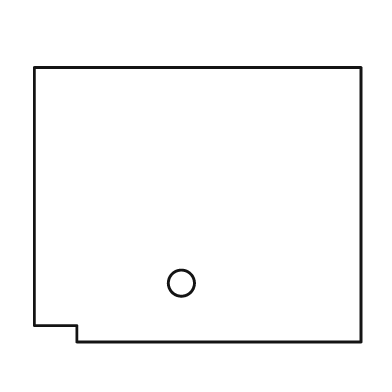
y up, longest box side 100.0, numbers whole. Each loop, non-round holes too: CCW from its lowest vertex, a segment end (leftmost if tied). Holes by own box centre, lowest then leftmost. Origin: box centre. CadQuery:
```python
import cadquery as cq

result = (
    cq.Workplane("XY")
    .moveTo(-37.0, -42.0)
    .lineTo(50.0, -42.0)
    .lineTo(50.0, 42.0)
    .lineTo(-50.0, 42.0)
    .lineTo(-50.0, -37.0)
    .lineTo(-37.0, -37.0)
    .close()
    .moveTo(-5.0, -24.0)
    .circle(4.0)
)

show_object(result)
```